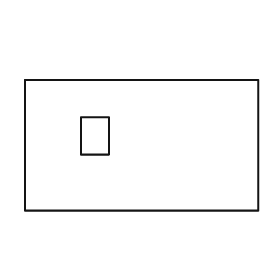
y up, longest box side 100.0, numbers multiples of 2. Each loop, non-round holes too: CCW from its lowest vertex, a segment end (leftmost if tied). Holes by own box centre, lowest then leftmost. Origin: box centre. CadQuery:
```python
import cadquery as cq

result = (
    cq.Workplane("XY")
    .moveTo(-50.0, -28.0)
    .lineTo(50.0, -28.0)
    .lineTo(50.0, 28.0)
    .lineTo(-50.0, 28.0)
    .close()
    .moveTo(-26.0, -4.0)
    .lineTo(-14.0, -4.0)
    .lineTo(-14.0, 12.0)
    .lineTo(-26.0, 12.0)
    .close()
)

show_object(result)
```